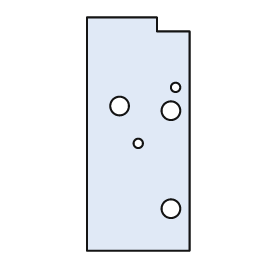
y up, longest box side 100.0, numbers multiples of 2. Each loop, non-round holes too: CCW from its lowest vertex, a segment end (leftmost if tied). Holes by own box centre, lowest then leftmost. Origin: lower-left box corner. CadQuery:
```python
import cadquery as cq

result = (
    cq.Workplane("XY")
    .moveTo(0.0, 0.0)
    .lineTo(44.0, 0.0)
    .lineTo(44.0, 94.0)
    .lineTo(30.0, 94.0)
    .lineTo(30.0, 100.0)
    .lineTo(0.0, 100.0)
    .close()
    .moveTo(36.0, 18.0)
    .circle(4.0)
    .moveTo(22.0, 46.0)
    .circle(2.0)
    .moveTo(36.0, 60.0)
    .circle(4.0)
    .moveTo(14.0, 62.0)
    .circle(4.0)
    .moveTo(38.0, 70.0)
    .circle(2.0)
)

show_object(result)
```